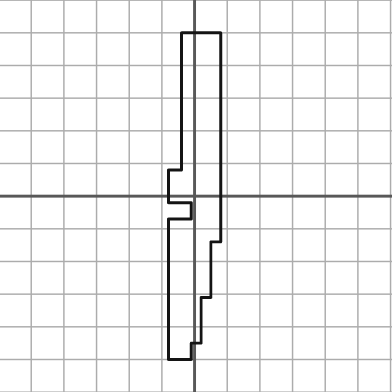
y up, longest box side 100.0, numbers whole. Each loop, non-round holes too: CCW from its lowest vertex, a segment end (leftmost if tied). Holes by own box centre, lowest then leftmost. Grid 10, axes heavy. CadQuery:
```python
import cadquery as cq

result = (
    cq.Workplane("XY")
    .moveTo(-8.0, -50.0)
    .lineTo(-1.0, -50.0)
    .lineTo(-1.0, -45.0)
    .lineTo(2.0, -45.0)
    .lineTo(2.0, -31.0)
    .lineTo(5.0, -31.0)
    .lineTo(5.0, -14.0)
    .lineTo(8.0, -14.0)
    .lineTo(8.0, 50.0)
    .lineTo(-4.0, 50.0)
    .lineTo(-4.0, 8.0)
    .lineTo(-8.0, 8.0)
    .lineTo(-8.0, -2.0)
    .lineTo(-1.0, -2.0)
    .lineTo(-1.0, -7.0)
    .lineTo(-8.0, -7.0)
    .close()
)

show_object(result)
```